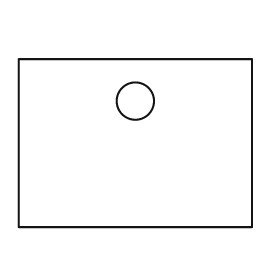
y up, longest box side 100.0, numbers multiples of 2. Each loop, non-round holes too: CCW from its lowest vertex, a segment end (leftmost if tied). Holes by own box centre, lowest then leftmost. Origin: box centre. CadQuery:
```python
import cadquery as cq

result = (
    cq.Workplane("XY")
    .moveTo(-50.0, -36.0)
    .lineTo(50.0, -36.0)
    .lineTo(50.0, 36.0)
    .lineTo(-50.0, 36.0)
    .close()
    .moveTo(0.0, 18.0)
    .circle(8.0)
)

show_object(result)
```